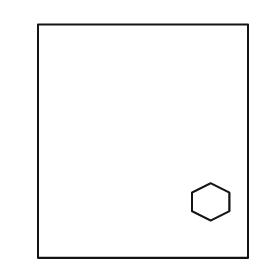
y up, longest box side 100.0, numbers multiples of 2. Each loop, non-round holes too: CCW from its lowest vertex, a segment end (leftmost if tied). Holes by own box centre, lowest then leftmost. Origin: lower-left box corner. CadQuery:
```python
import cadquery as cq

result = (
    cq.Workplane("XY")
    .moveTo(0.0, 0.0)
    .lineTo(90.0, 0.0)
    .lineTo(90.0, 100.0)
    .lineTo(0.0, 100.0)
    .close()
    .moveTo(74.0, 16.0)
    .lineTo(82.0, 20.0)
    .lineTo(82.0, 28.0)
    .lineTo(74.0, 32.0)
    .lineTo(66.0, 28.0)
    .lineTo(66.0, 20.0)
    .close()
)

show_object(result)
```